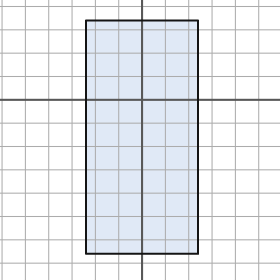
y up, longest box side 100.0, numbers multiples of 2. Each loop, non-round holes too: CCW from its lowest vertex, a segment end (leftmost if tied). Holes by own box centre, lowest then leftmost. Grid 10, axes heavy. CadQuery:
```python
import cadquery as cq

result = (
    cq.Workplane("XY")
    .moveTo(-24.0, -66.0)
    .lineTo(24.0, -66.0)
    .lineTo(24.0, 34.0)
    .lineTo(-24.0, 34.0)
    .close()
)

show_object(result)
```